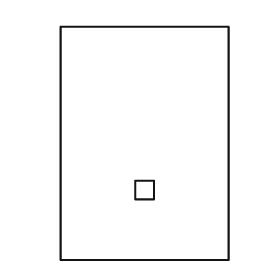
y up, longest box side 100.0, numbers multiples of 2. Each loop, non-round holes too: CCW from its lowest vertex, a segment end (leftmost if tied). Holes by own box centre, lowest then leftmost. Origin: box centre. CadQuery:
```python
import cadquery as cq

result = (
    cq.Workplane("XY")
    .moveTo(-36.0, -50.0)
    .lineTo(36.0, -50.0)
    .lineTo(36.0, 50.0)
    .lineTo(-36.0, 50.0)
    .close()
    .moveTo(-4.0, -24.0)
    .lineTo(4.0, -24.0)
    .lineTo(4.0, -16.0)
    .lineTo(-4.0, -16.0)
    .close()
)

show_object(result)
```